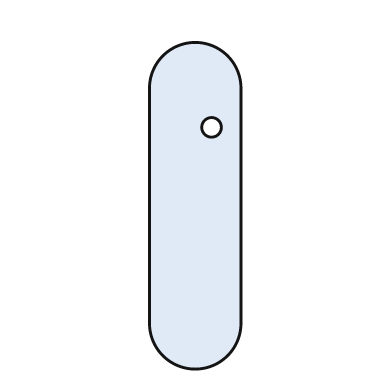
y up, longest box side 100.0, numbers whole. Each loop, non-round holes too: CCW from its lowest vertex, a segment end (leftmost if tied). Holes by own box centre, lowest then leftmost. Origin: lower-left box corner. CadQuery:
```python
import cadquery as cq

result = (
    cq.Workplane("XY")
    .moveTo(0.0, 14.0)
    .threePointArc((14.0, 0.0), (28.0, 14.0))
    .lineTo(28.0, 86.0)
    .threePointArc((14.0, 100.0), (0.0, 86.0))
    .close()
    .moveTo(19.0, 74.0)
    .circle(3.0)
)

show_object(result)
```